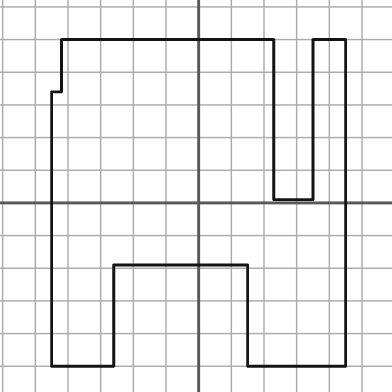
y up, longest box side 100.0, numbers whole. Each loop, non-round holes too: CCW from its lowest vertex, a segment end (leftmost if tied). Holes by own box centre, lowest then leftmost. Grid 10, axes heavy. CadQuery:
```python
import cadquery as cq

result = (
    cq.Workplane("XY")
    .moveTo(-45.0, -50.0)
    .lineTo(-26.0, -50.0)
    .lineTo(-26.0, -19.0)
    .lineTo(15.0, -19.0)
    .lineTo(15.0, -50.0)
    .lineTo(45.0, -50.0)
    .lineTo(45.0, 50.0)
    .lineTo(35.0, 50.0)
    .lineTo(35.0, 1.0)
    .lineTo(23.0, 1.0)
    .lineTo(23.0, 50.0)
    .lineTo(-42.0, 50.0)
    .lineTo(-42.0, 34.0)
    .lineTo(-45.0, 34.0)
    .close()
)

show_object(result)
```